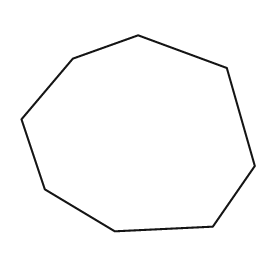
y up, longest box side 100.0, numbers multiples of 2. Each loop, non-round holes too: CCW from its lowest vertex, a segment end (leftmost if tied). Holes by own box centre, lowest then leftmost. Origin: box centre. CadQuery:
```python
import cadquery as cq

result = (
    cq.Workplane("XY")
    .moveTo(-10.0, -42.0)
    .lineTo(32.0, -40.0)
    .lineTo(50.0, -14.0)
    .lineTo(38.0, 28.0)
    .lineTo(0.0, 42.0)
    .lineTo(-28.0, 32.0)
    .lineTo(-50.0, 6.0)
    .lineTo(-40.0, -24.0)
    .close()
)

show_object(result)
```